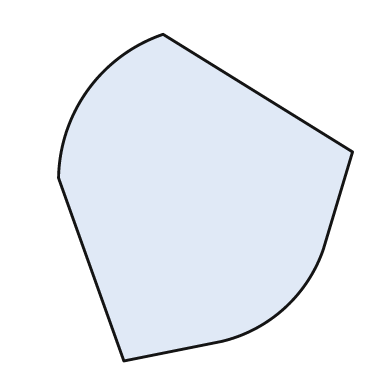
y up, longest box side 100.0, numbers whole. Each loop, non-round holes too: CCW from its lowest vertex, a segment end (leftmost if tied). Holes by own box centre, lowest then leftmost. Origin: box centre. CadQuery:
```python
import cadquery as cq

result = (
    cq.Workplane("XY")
    .moveTo(-25.0, -50.0)
    .lineTo(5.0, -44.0)
    .threePointArc((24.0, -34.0), (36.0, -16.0))
    .lineTo(45.0, 14.0)
    .lineTo(-13.0, 50.0)
    .threePointArc((-36.0, 33.0), (-45.0, 6.0))
    .close()
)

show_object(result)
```